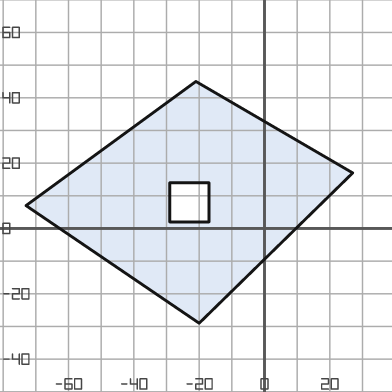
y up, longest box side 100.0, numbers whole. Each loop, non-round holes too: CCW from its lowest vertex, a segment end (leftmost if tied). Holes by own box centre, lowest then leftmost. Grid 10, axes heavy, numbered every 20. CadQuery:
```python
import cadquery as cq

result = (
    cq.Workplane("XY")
    .moveTo(-20.0, -29.0)
    .lineTo(27.0, 17.0)
    .lineTo(-21.0, 45.0)
    .lineTo(-73.0, 7.0)
    .close()
    .moveTo(-29.0, 2.0)
    .lineTo(-17.0, 2.0)
    .lineTo(-17.0, 14.0)
    .lineTo(-29.0, 14.0)
    .close()
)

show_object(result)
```